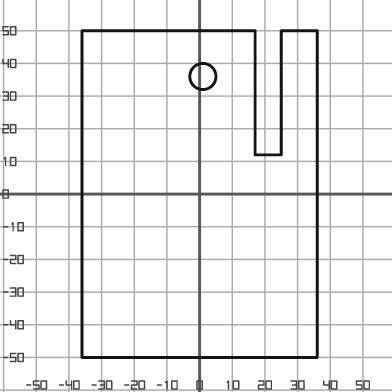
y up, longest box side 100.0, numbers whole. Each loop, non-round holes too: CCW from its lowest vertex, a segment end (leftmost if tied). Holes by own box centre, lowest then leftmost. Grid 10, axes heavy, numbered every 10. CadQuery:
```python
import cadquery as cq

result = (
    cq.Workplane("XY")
    .moveTo(-36.0, -50.0)
    .lineTo(36.0, -50.0)
    .lineTo(36.0, 50.0)
    .lineTo(25.0, 50.0)
    .lineTo(25.0, 12.0)
    .lineTo(17.0, 12.0)
    .lineTo(17.0, 50.0)
    .lineTo(-36.0, 50.0)
    .close()
    .moveTo(1.0, 36.0)
    .circle(4.0)
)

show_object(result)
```